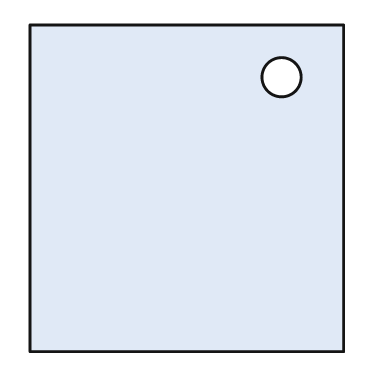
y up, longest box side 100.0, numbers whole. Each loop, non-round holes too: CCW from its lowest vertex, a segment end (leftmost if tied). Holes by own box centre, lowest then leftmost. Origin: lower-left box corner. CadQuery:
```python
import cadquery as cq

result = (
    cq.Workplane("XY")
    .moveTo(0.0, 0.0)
    .lineTo(96.0, 0.0)
    .lineTo(96.0, 100.0)
    .lineTo(0.0, 100.0)
    .close()
    .moveTo(77.0, 84.0)
    .circle(6.0)
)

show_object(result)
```